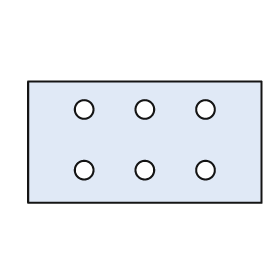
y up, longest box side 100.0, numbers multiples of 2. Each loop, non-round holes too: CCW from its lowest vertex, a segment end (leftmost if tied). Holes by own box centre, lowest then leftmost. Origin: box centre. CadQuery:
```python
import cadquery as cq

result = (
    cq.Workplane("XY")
    .moveTo(-50.0, -26.0)
    .lineTo(50.0, -26.0)
    .lineTo(50.0, 26.0)
    .lineTo(-50.0, 26.0)
    .close()
    .moveTo(-26.0, -12.0)
    .circle(4.0)
    .moveTo(0.0, -12.0)
    .circle(4.0)
    .moveTo(26.0, -12.0)
    .circle(4.0)
    .moveTo(-26.0, 14.0)
    .circle(4.0)
    .moveTo(0.0, 14.0)
    .circle(4.0)
    .moveTo(26.0, 14.0)
    .circle(4.0)
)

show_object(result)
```